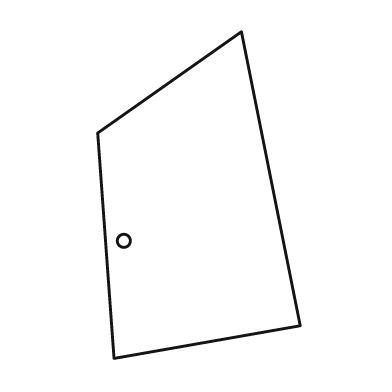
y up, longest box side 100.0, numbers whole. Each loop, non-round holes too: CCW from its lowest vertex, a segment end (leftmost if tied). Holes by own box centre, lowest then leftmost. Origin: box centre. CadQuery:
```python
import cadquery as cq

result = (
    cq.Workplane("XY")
    .moveTo(-26.0, -50.0)
    .lineTo(31.0, -40.0)
    .lineTo(13.0, 50.0)
    .lineTo(-31.0, 19.0)
    .close()
    .moveTo(-23.0, -14.0)
    .circle(2.0)
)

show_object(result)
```